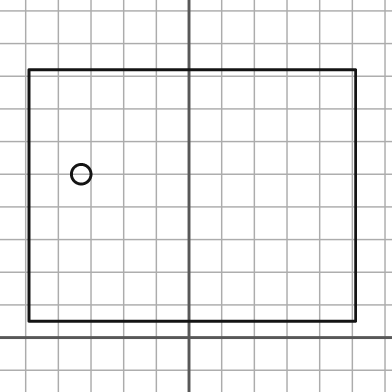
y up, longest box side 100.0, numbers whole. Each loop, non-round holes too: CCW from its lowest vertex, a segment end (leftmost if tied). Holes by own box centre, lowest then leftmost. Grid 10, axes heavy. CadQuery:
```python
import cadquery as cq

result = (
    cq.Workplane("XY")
    .moveTo(-49.0, 5.0)
    .lineTo(51.0, 5.0)
    .lineTo(51.0, 82.0)
    .lineTo(-49.0, 82.0)
    .close()
    .moveTo(-33.0, 50.0)
    .circle(3.0)
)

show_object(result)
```